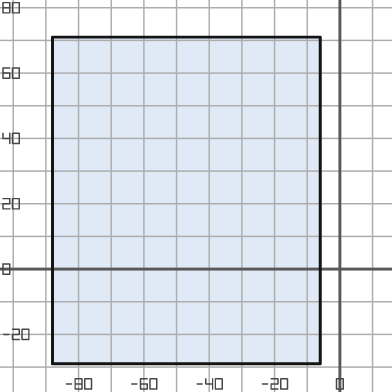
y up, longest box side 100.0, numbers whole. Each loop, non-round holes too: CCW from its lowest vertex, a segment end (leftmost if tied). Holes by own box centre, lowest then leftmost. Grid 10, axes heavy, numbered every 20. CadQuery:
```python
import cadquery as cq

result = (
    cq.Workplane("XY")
    .moveTo(-88.0, -29.0)
    .lineTo(-6.0, -29.0)
    .lineTo(-6.0, 71.0)
    .lineTo(-88.0, 71.0)
    .close()
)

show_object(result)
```